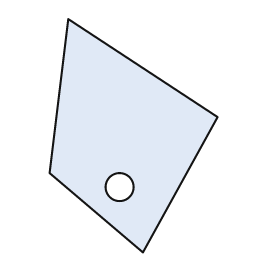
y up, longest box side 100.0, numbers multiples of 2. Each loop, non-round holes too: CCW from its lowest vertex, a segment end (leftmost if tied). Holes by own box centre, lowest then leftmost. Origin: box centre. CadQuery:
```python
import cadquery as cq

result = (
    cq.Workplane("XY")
    .moveTo(4.0, -50.0)
    .lineTo(36.0, 8.0)
    .lineTo(-28.0, 50.0)
    .lineTo(-36.0, -16.0)
    .close()
    .moveTo(-6.0, -22.0)
    .circle(6.0)
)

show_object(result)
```